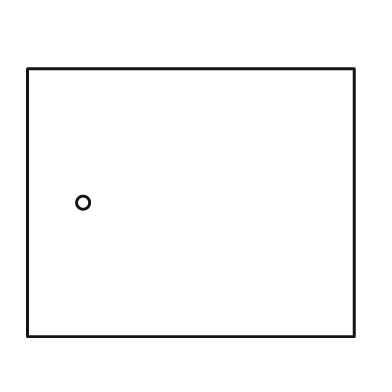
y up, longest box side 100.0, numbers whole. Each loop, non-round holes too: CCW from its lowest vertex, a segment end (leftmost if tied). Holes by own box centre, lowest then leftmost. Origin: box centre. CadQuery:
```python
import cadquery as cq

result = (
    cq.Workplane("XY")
    .moveTo(-50.0, -41.0)
    .lineTo(50.0, -41.0)
    .lineTo(50.0, 41.0)
    .lineTo(-50.0, 41.0)
    .close()
    .moveTo(-33.0, 0.0)
    .circle(2.0)
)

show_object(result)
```